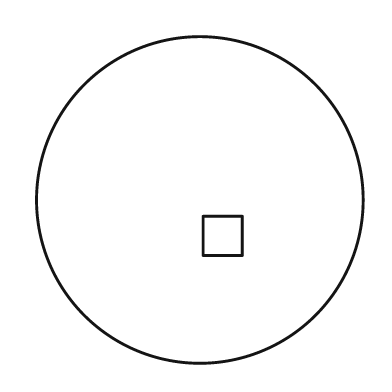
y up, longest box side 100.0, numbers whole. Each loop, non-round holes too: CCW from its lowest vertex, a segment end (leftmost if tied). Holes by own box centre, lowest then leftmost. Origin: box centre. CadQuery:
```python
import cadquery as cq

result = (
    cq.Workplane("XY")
    .moveTo(0.0, 0.0)
    .circle(50.0)
    .moveTo(1.0, -17.0)
    .lineTo(13.0, -17.0)
    .lineTo(13.0, -5.0)
    .lineTo(1.0, -5.0)
    .close()
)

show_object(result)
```